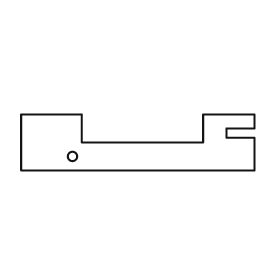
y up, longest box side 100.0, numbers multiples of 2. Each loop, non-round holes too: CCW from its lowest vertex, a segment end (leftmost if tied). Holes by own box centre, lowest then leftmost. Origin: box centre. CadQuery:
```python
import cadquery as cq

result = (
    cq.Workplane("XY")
    .moveTo(-50.0, -12.0)
    .lineTo(50.0, -12.0)
    .lineTo(50.0, 2.0)
    .lineTo(38.0, 2.0)
    .lineTo(38.0, 6.0)
    .lineTo(50.0, 6.0)
    .lineTo(50.0, 12.0)
    .lineTo(28.0, 12.0)
    .lineTo(28.0, 0.0)
    .lineTo(-24.0, 0.0)
    .lineTo(-24.0, 12.0)
    .lineTo(-50.0, 12.0)
    .close()
    .moveTo(-28.0, -6.0)
    .circle(2.0)
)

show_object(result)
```